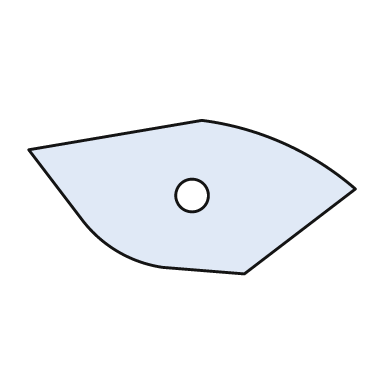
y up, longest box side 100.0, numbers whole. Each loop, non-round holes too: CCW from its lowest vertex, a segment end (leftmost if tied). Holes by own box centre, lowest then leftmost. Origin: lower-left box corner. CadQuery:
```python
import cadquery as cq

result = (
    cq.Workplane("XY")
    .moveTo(66.0, 0.0)
    .lineTo(100.0, 26.0)
    .threePointArc((78.0, 40.0), (53.0, 47.0))
    .lineTo(0.0, 38.0)
    .lineTo(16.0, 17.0)
    .threePointArc((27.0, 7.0), (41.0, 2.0))
    .close()
    .moveTo(50.0, 24.0)
    .circle(5.0)
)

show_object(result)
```